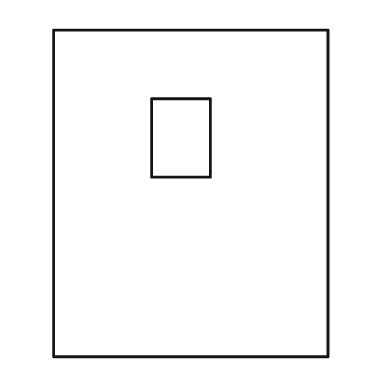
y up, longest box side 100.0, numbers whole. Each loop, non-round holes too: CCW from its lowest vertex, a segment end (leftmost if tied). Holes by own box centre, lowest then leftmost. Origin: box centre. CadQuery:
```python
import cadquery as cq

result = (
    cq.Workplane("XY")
    .moveTo(-42.0, -50.0)
    .lineTo(42.0, -50.0)
    .lineTo(42.0, 50.0)
    .lineTo(-42.0, 50.0)
    .close()
    .moveTo(-12.0, 5.0)
    .lineTo(6.0, 5.0)
    .lineTo(6.0, 29.0)
    .lineTo(-12.0, 29.0)
    .close()
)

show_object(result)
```